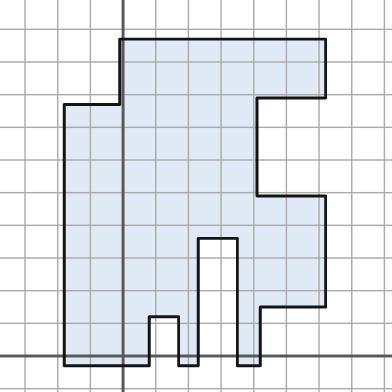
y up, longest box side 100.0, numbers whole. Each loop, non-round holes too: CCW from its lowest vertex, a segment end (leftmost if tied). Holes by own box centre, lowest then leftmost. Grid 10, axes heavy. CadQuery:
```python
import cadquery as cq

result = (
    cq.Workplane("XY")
    .moveTo(-18.0, -3.0)
    .lineTo(8.0, -3.0)
    .lineTo(8.0, 12.0)
    .lineTo(17.0, 12.0)
    .lineTo(17.0, -3.0)
    .lineTo(23.0, -3.0)
    .lineTo(23.0, 36.0)
    .lineTo(35.0, 36.0)
    .lineTo(35.0, -3.0)
    .lineTo(42.0, -3.0)
    .lineTo(42.0, 15.0)
    .lineTo(62.0, 15.0)
    .lineTo(62.0, 49.0)
    .lineTo(41.0, 49.0)
    .lineTo(41.0, 79.0)
    .lineTo(62.0, 79.0)
    .lineTo(62.0, 97.0)
    .lineTo(-1.0, 97.0)
    .lineTo(-1.0, 77.0)
    .lineTo(-18.0, 77.0)
    .close()
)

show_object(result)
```